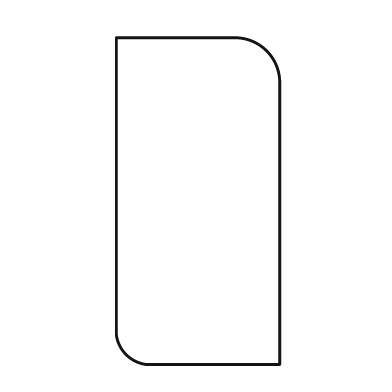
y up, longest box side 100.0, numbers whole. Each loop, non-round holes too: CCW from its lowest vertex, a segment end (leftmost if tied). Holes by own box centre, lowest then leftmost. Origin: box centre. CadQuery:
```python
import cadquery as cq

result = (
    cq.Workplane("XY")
    .moveTo(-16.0, -50.0)
    .lineTo(25.0, -50.0)
    .lineTo(25.0, 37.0)
    .threePointArc((21.0, 46.0), (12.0, 50.0))
    .lineTo(-25.0, 50.0)
    .lineTo(-25.0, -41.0)
    .threePointArc((-22.0, -47.0), (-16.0, -50.0))
    .close()
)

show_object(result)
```